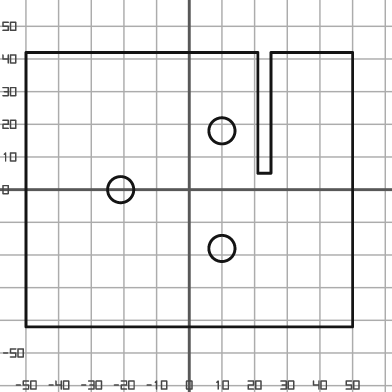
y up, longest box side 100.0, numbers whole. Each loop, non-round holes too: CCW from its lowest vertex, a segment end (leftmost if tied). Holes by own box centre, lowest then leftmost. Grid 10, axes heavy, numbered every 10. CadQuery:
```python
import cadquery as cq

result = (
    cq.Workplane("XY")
    .moveTo(-50.0, -42.0)
    .lineTo(50.0, -42.0)
    .lineTo(50.0, 42.0)
    .lineTo(25.0, 42.0)
    .lineTo(25.0, 5.0)
    .lineTo(21.0, 5.0)
    .lineTo(21.0, 42.0)
    .lineTo(-50.0, 42.0)
    .close()
    .moveTo(10.0, -18.0)
    .circle(4.0)
    .moveTo(-21.0, 0.0)
    .circle(4.0)
    .moveTo(10.0, 18.0)
    .circle(4.0)
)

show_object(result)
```